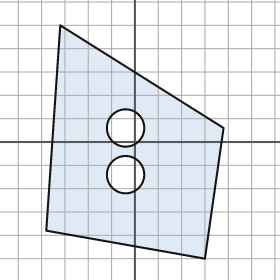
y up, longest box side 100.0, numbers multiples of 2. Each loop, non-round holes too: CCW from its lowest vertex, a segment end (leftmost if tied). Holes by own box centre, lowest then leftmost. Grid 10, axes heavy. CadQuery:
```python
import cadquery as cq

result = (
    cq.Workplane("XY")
    .moveTo(30.0, -50.0)
    .lineTo(38.0, 6.0)
    .lineTo(-32.0, 50.0)
    .lineTo(-38.0, -38.0)
    .close()
    .moveTo(-4.0, -14.0)
    .circle(8.0)
    .moveTo(-4.0, 6.0)
    .circle(8.0)
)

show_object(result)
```